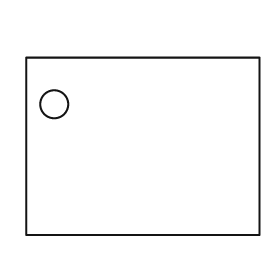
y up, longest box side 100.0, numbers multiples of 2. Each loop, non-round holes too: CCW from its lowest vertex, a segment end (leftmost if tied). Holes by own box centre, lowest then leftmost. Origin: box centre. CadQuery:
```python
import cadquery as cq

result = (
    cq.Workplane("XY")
    .moveTo(-50.0, -38.0)
    .lineTo(50.0, -38.0)
    .lineTo(50.0, 38.0)
    .lineTo(-50.0, 38.0)
    .close()
    .moveTo(-38.0, 18.0)
    .circle(6.0)
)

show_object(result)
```